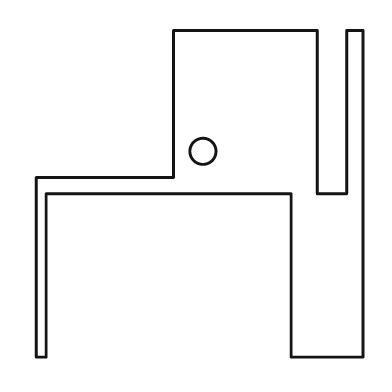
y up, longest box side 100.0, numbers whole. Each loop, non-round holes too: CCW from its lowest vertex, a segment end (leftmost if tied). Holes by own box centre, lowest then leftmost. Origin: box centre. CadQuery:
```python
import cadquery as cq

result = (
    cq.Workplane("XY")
    .moveTo(-50.0, -50.0)
    .lineTo(-47.0, -50.0)
    .lineTo(-47.0, 0.0)
    .lineTo(28.0, 0.0)
    .lineTo(28.0, -50.0)
    .lineTo(50.0, -50.0)
    .lineTo(50.0, 50.0)
    .lineTo(45.0, 50.0)
    .lineTo(45.0, 0.0)
    .lineTo(36.0, 0.0)
    .lineTo(36.0, 50.0)
    .lineTo(-8.0, 50.0)
    .lineTo(-8.0, 5.0)
    .lineTo(-50.0, 5.0)
    .close()
    .moveTo(1.0, 13.0)
    .circle(4.0)
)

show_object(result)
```